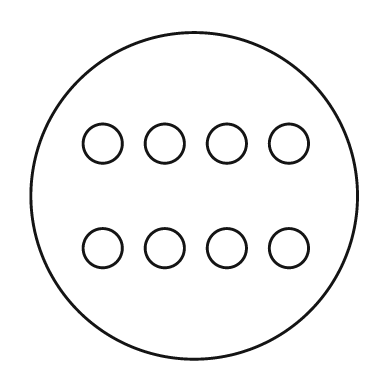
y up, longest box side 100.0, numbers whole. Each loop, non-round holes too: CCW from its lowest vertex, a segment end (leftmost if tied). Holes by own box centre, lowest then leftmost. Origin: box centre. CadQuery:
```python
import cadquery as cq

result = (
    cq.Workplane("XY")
    .moveTo(0.0, 0.0)
    .circle(50.0)
    .moveTo(-28.0, -16.0)
    .circle(6.0)
    .moveTo(-9.0, -16.0)
    .circle(6.0)
    .moveTo(10.0, -16.0)
    .circle(6.0)
    .moveTo(29.0, -16.0)
    .circle(6.0)
    .moveTo(-28.0, 16.0)
    .circle(6.0)
    .moveTo(-9.0, 16.0)
    .circle(6.0)
    .moveTo(10.0, 16.0)
    .circle(6.0)
    .moveTo(29.0, 16.0)
    .circle(6.0)
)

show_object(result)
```